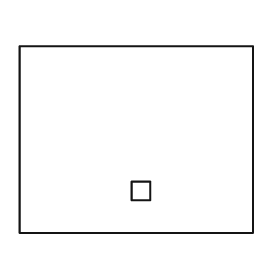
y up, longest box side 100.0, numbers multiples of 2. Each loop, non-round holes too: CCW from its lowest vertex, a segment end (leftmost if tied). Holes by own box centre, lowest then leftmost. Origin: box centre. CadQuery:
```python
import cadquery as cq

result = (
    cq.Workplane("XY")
    .moveTo(-50.0, -40.0)
    .lineTo(50.0, -40.0)
    .lineTo(50.0, 40.0)
    .lineTo(-50.0, 40.0)
    .close()
    .moveTo(-2.0, -26.0)
    .lineTo(6.0, -26.0)
    .lineTo(6.0, -18.0)
    .lineTo(-2.0, -18.0)
    .close()
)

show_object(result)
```